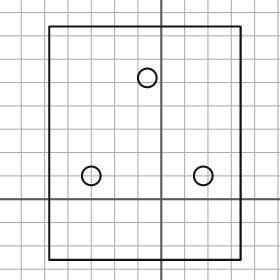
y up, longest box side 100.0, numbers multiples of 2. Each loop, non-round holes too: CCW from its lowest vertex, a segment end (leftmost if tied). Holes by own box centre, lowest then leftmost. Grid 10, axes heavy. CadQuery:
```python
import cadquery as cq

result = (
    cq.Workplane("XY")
    .moveTo(-48.0, -26.0)
    .lineTo(34.0, -26.0)
    .lineTo(34.0, 74.0)
    .lineTo(-48.0, 74.0)
    .close()
    .moveTo(-30.0, 10.0)
    .circle(4.0)
    .moveTo(18.0, 10.0)
    .circle(4.0)
    .moveTo(-6.0, 52.0)
    .circle(4.0)
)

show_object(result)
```